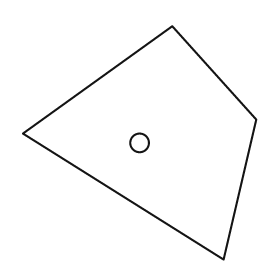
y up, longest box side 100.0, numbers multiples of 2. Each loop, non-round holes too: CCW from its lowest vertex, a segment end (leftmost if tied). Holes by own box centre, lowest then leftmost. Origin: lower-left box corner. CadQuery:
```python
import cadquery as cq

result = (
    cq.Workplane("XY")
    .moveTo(86.0, 0.0)
    .lineTo(100.0, 60.0)
    .lineTo(64.0, 100.0)
    .lineTo(0.0, 54.0)
    .close()
    .moveTo(50.0, 50.0)
    .circle(4.0)
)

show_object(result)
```